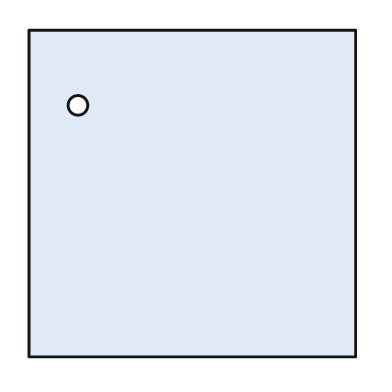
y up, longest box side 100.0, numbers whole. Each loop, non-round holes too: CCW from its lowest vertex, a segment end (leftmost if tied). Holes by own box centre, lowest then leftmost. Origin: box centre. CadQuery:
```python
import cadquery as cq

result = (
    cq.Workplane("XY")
    .moveTo(-50.0, -50.0)
    .lineTo(50.0, -50.0)
    .lineTo(50.0, 50.0)
    .lineTo(-50.0, 50.0)
    .close()
    .moveTo(-35.0, 27.0)
    .circle(3.0)
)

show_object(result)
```